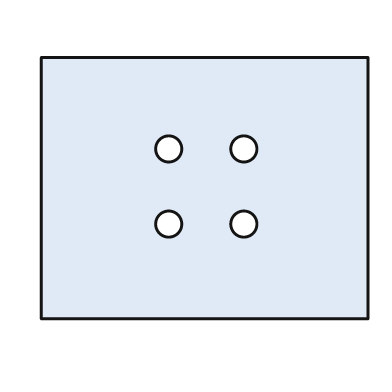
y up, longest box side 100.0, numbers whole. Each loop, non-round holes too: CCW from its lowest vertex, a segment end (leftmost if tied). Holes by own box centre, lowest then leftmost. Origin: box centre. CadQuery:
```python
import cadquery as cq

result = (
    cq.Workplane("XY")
    .moveTo(-50.0, -40.0)
    .lineTo(50.0, -40.0)
    .lineTo(50.0, 40.0)
    .lineTo(-50.0, 40.0)
    .close()
    .moveTo(-11.0, -11.0)
    .circle(4.0)
    .moveTo(12.0, -11.0)
    .circle(4.0)
    .moveTo(-11.0, 12.0)
    .circle(4.0)
    .moveTo(12.0, 12.0)
    .circle(4.0)
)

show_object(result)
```